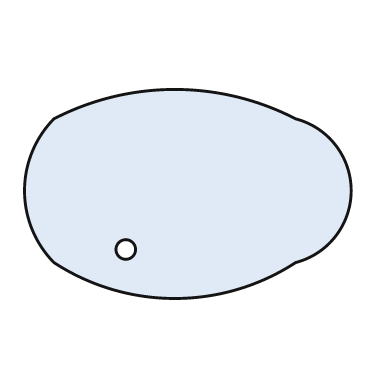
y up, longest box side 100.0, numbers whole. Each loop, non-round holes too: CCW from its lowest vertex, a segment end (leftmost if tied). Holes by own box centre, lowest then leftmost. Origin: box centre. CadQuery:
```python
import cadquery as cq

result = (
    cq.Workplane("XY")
    .moveTo(-41.0, -21.0)
    .threePointArc((-4.0, -32.0), (33.0, -21.0))
    .threePointArc((50.0, 1.0), (33.0, 23.0))
    .threePointArc((-4.0, 32.0), (-41.0, 23.0))
    .threePointArc((-50.0, 1.0), (-41.0, -21.0))
    .close()
    .moveTo(-19.0, -17.0)
    .circle(3.0)
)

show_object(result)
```